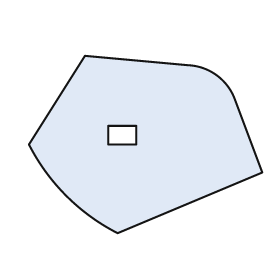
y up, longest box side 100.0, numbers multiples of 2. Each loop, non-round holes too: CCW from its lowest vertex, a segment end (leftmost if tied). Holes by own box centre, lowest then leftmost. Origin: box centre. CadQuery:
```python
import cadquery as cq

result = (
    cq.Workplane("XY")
    .moveTo(-12.0, -38.0)
    .lineTo(50.0, -12.0)
    .lineTo(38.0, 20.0)
    .threePointArc((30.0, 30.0), (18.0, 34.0))
    .lineTo(-26.0, 38.0)
    .lineTo(-50.0, 0.0)
    .threePointArc((-34.0, -22.0), (-12.0, -38.0))
    .close()
    .moveTo(-16.0, 0.0)
    .lineTo(-4.0, 0.0)
    .lineTo(-4.0, 8.0)
    .lineTo(-16.0, 8.0)
    .close()
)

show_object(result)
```